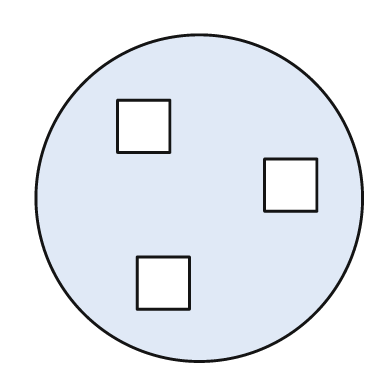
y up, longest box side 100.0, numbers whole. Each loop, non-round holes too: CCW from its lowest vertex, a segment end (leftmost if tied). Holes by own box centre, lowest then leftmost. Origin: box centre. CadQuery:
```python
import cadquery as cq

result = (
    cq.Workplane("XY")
    .moveTo(0.0, 0.0)
    .circle(50.0)
    .moveTo(-19.0, -34.0)
    .lineTo(-3.0, -34.0)
    .lineTo(-3.0, -18.0)
    .lineTo(-19.0, -18.0)
    .close()
    .moveTo(20.0, -4.0)
    .lineTo(36.0, -4.0)
    .lineTo(36.0, 12.0)
    .lineTo(20.0, 12.0)
    .close()
    .moveTo(-25.0, 14.0)
    .lineTo(-9.0, 14.0)
    .lineTo(-9.0, 30.0)
    .lineTo(-25.0, 30.0)
    .close()
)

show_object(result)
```